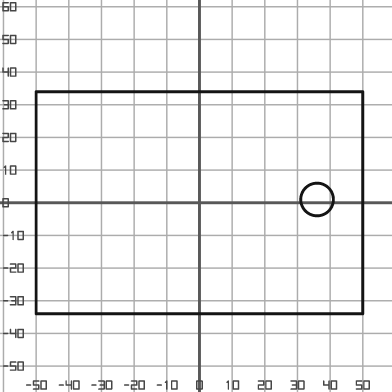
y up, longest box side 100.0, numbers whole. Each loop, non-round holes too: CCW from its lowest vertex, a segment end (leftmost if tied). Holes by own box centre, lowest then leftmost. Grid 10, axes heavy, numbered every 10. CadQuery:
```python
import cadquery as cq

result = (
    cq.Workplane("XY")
    .moveTo(-50.0, -34.0)
    .lineTo(50.0, -34.0)
    .lineTo(50.0, 34.0)
    .lineTo(-50.0, 34.0)
    .close()
    .moveTo(36.0, 1.0)
    .circle(5.0)
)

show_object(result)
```